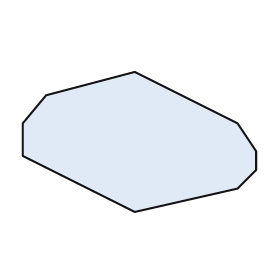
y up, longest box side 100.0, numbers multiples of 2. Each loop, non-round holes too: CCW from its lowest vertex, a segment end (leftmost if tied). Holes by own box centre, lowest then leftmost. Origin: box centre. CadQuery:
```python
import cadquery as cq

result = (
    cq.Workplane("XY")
    .moveTo(-2.0, -30.0)
    .lineTo(42.0, -20.0)
    .lineTo(50.0, -12.0)
    .lineTo(50.0, -4.0)
    .lineTo(42.0, 8.0)
    .lineTo(-2.0, 30.0)
    .lineTo(-40.0, 20.0)
    .lineTo(-50.0, 8.0)
    .lineTo(-50.0, -6.0)
    .close()
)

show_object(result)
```